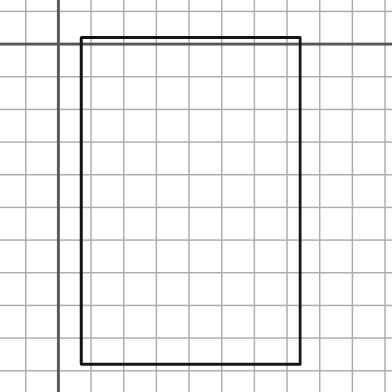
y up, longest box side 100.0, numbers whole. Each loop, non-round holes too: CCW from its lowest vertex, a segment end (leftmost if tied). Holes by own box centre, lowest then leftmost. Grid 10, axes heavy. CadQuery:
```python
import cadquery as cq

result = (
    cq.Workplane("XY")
    .moveTo(7.0, -98.0)
    .lineTo(74.0, -98.0)
    .lineTo(74.0, 2.0)
    .lineTo(7.0, 2.0)
    .close()
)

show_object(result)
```